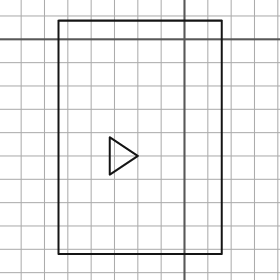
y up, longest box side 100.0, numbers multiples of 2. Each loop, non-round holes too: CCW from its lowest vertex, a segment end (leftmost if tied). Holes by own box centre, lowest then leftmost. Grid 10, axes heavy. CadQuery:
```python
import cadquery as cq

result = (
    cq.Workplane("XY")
    .moveTo(-54.0, -92.0)
    .lineTo(16.0, -92.0)
    .lineTo(16.0, 8.0)
    .lineTo(-54.0, 8.0)
    .close()
    .moveTo(-32.0, -58.0)
    .lineTo(-20.0, -50.0)
    .lineTo(-32.0, -42.0)
    .close()
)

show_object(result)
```